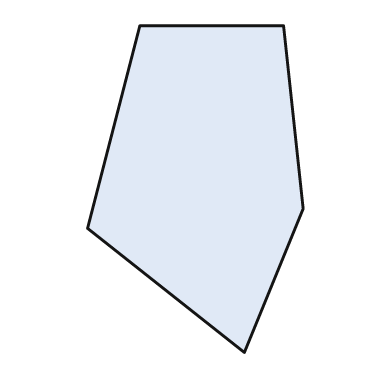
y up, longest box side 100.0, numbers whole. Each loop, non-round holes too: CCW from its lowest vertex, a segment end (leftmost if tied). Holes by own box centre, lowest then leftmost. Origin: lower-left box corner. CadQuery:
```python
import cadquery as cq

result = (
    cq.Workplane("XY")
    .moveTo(48.0, 0.0)
    .lineTo(66.0, 44.0)
    .lineTo(60.0, 100.0)
    .lineTo(16.0, 100.0)
    .lineTo(0.0, 38.0)
    .close()
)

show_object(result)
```